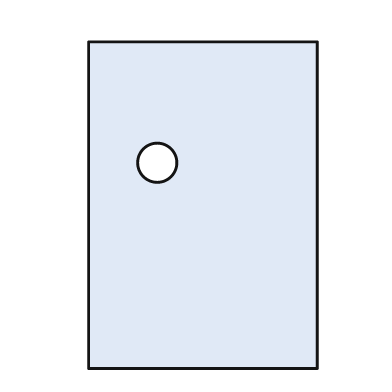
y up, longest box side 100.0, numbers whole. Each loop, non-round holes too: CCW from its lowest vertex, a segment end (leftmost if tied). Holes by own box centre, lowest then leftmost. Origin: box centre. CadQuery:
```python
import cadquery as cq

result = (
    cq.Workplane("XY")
    .moveTo(-35.0, -50.0)
    .lineTo(35.0, -50.0)
    .lineTo(35.0, 50.0)
    .lineTo(-35.0, 50.0)
    .close()
    .moveTo(-14.0, 13.0)
    .circle(6.0)
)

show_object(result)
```